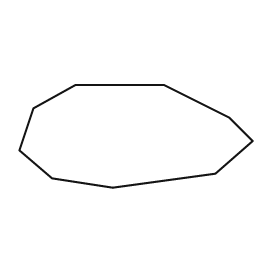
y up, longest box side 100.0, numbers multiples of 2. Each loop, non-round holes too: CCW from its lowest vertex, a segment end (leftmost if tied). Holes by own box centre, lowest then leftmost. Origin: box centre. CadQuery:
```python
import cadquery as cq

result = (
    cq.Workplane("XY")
    .moveTo(-10.0, -22.0)
    .lineTo(34.0, -16.0)
    .lineTo(50.0, -2.0)
    .lineTo(40.0, 8.0)
    .lineTo(12.0, 22.0)
    .lineTo(-26.0, 22.0)
    .lineTo(-44.0, 12.0)
    .lineTo(-50.0, -6.0)
    .lineTo(-36.0, -18.0)
    .close()
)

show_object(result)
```